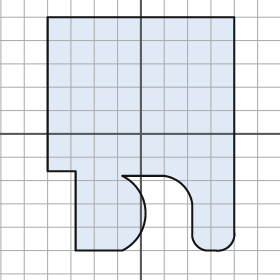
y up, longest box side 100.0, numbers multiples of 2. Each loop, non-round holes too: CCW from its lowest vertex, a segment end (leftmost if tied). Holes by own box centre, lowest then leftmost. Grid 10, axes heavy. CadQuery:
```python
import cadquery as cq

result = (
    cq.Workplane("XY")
    .moveTo(-28.0, -50.0)
    .lineTo(-8.0, -50.0)
    .threePointArc((2.0, -34.0), (-8.0, -18.0))
    .lineTo(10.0, -18.0)
    .threePointArc((18.0, -22.0), (22.0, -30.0))
    .lineTo(22.0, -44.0)
    .threePointArc((24.0, -48.0), (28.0, -50.0))
    .lineTo(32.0, -50.0)
    .threePointArc((38.0, -48.0), (40.0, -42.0))
    .lineTo(40.0, 50.0)
    .lineTo(-40.0, 50.0)
    .lineTo(-40.0, -16.0)
    .lineTo(-28.0, -16.0)
    .close()
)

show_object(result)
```